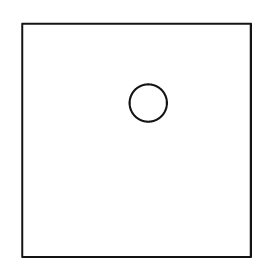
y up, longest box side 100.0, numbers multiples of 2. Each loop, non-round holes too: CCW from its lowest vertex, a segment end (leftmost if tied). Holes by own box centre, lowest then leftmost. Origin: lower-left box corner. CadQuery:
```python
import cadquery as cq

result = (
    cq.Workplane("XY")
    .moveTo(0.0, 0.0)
    .lineTo(98.0, 0.0)
    .lineTo(98.0, 100.0)
    .lineTo(0.0, 100.0)
    .close()
    .moveTo(54.0, 66.0)
    .circle(8.0)
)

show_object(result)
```